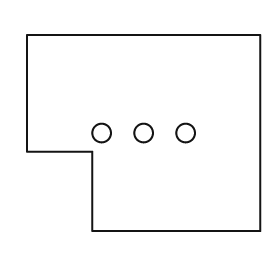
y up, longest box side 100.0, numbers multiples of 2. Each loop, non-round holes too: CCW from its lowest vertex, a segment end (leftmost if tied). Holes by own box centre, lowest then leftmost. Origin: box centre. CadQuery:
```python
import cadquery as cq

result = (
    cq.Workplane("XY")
    .moveTo(-22.0, -42.0)
    .lineTo(50.0, -42.0)
    .lineTo(50.0, 42.0)
    .lineTo(-50.0, 42.0)
    .lineTo(-50.0, -8.0)
    .lineTo(-22.0, -8.0)
    .close()
    .moveTo(-18.0, 0.0)
    .circle(4.0)
    .moveTo(0.0, 0.0)
    .circle(4.0)
    .moveTo(18.0, 0.0)
    .circle(4.0)
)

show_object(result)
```